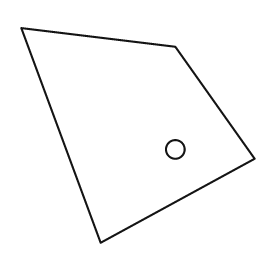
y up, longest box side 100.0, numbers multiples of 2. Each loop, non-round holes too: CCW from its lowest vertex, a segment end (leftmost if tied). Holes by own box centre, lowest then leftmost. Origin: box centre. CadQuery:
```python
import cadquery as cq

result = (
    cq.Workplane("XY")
    .moveTo(-16.0, -46.0)
    .lineTo(50.0, -10.0)
    .lineTo(16.0, 38.0)
    .lineTo(-50.0, 46.0)
    .close()
    .moveTo(16.0, -6.0)
    .circle(4.0)
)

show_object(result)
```